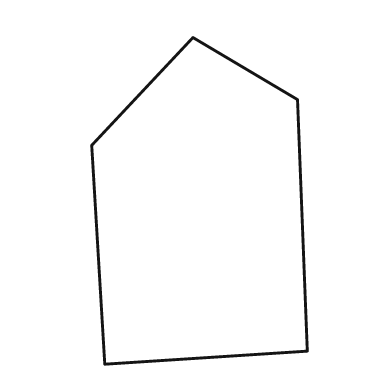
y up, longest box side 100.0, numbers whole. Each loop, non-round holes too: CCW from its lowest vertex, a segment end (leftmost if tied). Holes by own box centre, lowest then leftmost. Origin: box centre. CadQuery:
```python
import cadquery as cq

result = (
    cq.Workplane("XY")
    .moveTo(-29.0, -50.0)
    .lineTo(33.0, -46.0)
    .lineTo(30.0, 31.0)
    .lineTo(-2.0, 50.0)
    .lineTo(-33.0, 17.0)
    .close()
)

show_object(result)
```